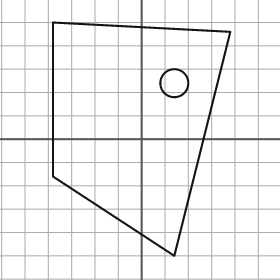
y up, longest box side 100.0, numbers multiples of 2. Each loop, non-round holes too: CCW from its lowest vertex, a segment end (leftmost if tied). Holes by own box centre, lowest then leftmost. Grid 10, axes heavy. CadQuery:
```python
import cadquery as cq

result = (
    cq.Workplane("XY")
    .moveTo(14.0, -50.0)
    .lineTo(38.0, 46.0)
    .lineTo(-38.0, 50.0)
    .lineTo(-38.0, -16.0)
    .close()
    .moveTo(14.0, 24.0)
    .circle(6.0)
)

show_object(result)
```